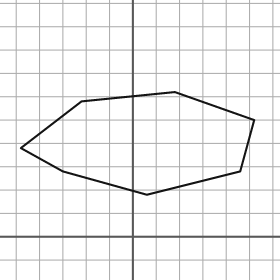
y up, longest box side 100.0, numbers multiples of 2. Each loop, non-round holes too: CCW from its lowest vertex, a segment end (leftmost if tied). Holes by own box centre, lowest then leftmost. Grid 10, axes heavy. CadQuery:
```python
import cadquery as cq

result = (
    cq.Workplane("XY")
    .moveTo(6.0, 18.0)
    .lineTo(46.0, 28.0)
    .lineTo(52.0, 50.0)
    .lineTo(18.0, 62.0)
    .lineTo(-22.0, 58.0)
    .lineTo(-48.0, 38.0)
    .lineTo(-30.0, 28.0)
    .close()
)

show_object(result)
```